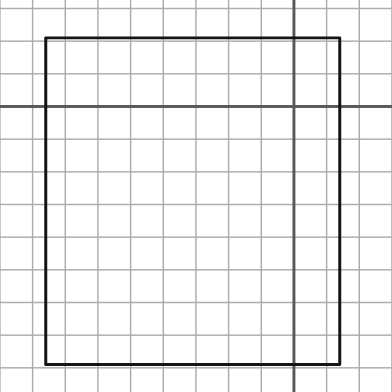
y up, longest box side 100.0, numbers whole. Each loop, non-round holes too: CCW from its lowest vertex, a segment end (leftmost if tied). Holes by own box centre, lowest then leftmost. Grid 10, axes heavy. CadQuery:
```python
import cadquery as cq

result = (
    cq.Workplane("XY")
    .moveTo(-76.0, -79.0)
    .lineTo(14.0, -79.0)
    .lineTo(14.0, 21.0)
    .lineTo(-76.0, 21.0)
    .close()
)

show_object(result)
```